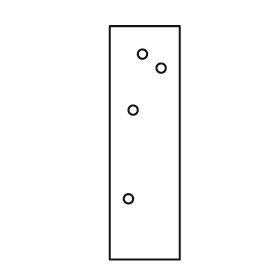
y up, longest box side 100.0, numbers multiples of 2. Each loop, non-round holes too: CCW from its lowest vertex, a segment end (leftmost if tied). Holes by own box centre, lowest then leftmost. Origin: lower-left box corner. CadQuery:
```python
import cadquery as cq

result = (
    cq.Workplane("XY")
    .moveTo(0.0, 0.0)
    .lineTo(30.0, 0.0)
    .lineTo(30.0, 100.0)
    .lineTo(0.0, 100.0)
    .close()
    .moveTo(8.0, 26.0)
    .circle(2.0)
    .moveTo(10.0, 64.0)
    .circle(2.0)
    .moveTo(22.0, 82.0)
    .circle(2.0)
    .moveTo(14.0, 88.0)
    .circle(2.0)
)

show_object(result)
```